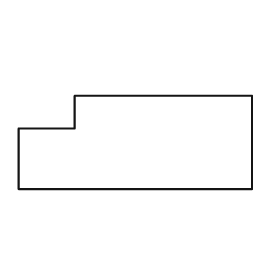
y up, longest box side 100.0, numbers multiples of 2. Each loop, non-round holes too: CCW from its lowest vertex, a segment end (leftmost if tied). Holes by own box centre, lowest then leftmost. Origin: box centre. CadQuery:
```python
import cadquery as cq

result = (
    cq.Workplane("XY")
    .moveTo(-50.0, -20.0)
    .lineTo(50.0, -20.0)
    .lineTo(50.0, 20.0)
    .lineTo(-26.0, 20.0)
    .lineTo(-26.0, 6.0)
    .lineTo(-50.0, 6.0)
    .close()
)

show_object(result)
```